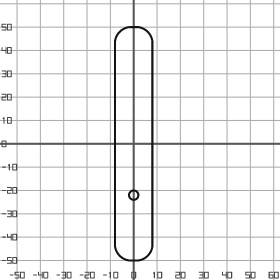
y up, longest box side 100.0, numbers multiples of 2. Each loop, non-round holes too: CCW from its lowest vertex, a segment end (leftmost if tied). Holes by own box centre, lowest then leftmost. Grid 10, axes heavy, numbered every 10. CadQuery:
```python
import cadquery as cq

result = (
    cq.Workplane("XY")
    .moveTo(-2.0, -50.0)
    .lineTo(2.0, -50.0)
    .threePointArc((6.0, -48.0), (8.0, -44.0))
    .lineTo(8.0, 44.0)
    .threePointArc((6.0, 48.0), (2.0, 50.0))
    .lineTo(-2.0, 50.0)
    .threePointArc((-6.0, 48.0), (-8.0, 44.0))
    .lineTo(-8.0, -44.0)
    .threePointArc((-6.0, -48.0), (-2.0, -50.0))
    .close()
    .moveTo(0.0, -22.0)
    .circle(2.0)
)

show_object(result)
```